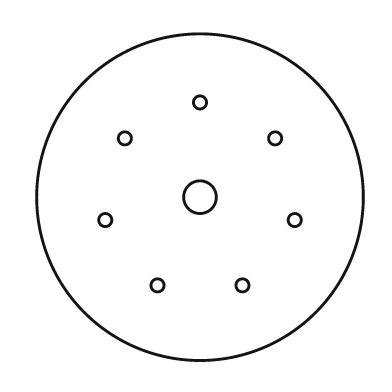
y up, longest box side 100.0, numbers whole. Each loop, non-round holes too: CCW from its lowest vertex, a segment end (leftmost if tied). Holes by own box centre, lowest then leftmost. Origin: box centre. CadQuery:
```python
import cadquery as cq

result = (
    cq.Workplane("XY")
    .moveTo(0.0, 0.0)
    .circle(50.0)
    .moveTo(-13.0, -27.0)
    .circle(2.0)
    .moveTo(13.0, -27.0)
    .circle(2.0)
    .moveTo(-29.0, -7.0)
    .circle(2.0)
    .moveTo(29.0, -7.0)
    .circle(2.0)
    .moveTo(0.0, 0.0)
    .circle(5.0)
    .moveTo(-23.0, 18.0)
    .circle(2.0)
    .moveTo(23.0, 18.0)
    .circle(2.0)
    .moveTo(0.0, 29.0)
    .circle(2.0)
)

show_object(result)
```